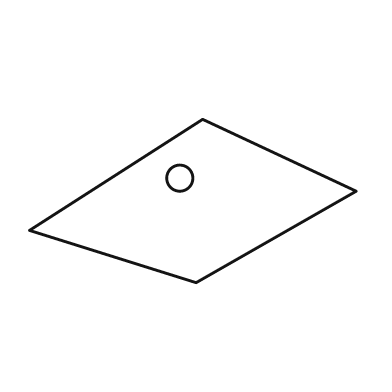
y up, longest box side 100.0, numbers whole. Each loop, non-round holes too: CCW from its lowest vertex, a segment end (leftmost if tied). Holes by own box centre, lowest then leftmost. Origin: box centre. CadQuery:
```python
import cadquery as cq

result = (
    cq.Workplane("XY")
    .moveTo(1.0, -25.0)
    .lineTo(50.0, 3.0)
    .lineTo(3.0, 25.0)
    .lineTo(-50.0, -9.0)
    .close()
    .moveTo(-4.0, 7.0)
    .circle(4.0)
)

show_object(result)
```